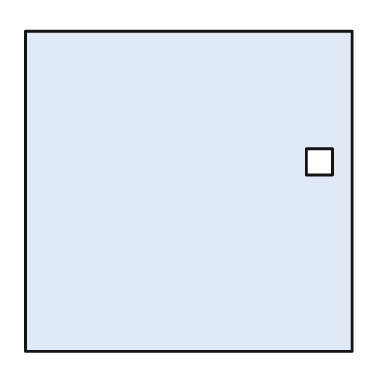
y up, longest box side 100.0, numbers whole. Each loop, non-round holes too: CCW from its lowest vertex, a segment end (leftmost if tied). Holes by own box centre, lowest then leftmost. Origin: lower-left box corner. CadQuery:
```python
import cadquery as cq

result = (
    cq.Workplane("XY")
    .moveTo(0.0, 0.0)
    .lineTo(100.0, 0.0)
    .lineTo(100.0, 98.0)
    .lineTo(0.0, 98.0)
    .close()
    .moveTo(86.0, 54.0)
    .lineTo(94.0, 54.0)
    .lineTo(94.0, 62.0)
    .lineTo(86.0, 62.0)
    .close()
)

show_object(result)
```